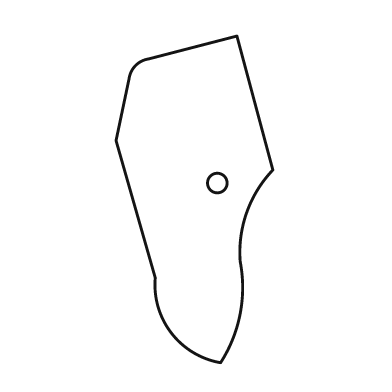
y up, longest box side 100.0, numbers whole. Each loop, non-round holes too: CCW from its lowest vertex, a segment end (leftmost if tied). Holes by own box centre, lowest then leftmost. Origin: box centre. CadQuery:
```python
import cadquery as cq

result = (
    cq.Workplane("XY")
    .moveTo(8.0, -50.0)
    .threePointArc((14.0, -35.0), (14.0, -19.0))
    .threePointArc((16.0, -4.0), (24.0, 9.0))
    .lineTo(13.0, 50.0)
    .lineTo(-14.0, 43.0)
    .threePointArc((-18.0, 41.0), (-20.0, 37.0))
    .lineTo(-24.0, 18.0)
    .lineTo(-12.0, -24.0)
    .threePointArc((-7.0, -41.0), (8.0, -50.0))
    .close()
    .moveTo(7.0, 5.0)
    .circle(3.0)
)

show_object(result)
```